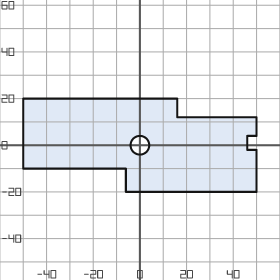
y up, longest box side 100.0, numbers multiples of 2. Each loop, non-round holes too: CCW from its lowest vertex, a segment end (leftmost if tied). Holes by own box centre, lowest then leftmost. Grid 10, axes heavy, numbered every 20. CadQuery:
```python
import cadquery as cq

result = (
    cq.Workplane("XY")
    .moveTo(-6.0, -20.0)
    .lineTo(50.0, -20.0)
    .lineTo(50.0, -2.0)
    .lineTo(46.0, -2.0)
    .lineTo(46.0, 4.0)
    .lineTo(50.0, 4.0)
    .lineTo(50.0, 12.0)
    .lineTo(16.0, 12.0)
    .lineTo(16.0, 20.0)
    .lineTo(-50.0, 20.0)
    .lineTo(-50.0, -10.0)
    .lineTo(-6.0, -10.0)
    .close()
    .moveTo(0.0, 0.0)
    .circle(4.0)
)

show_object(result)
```